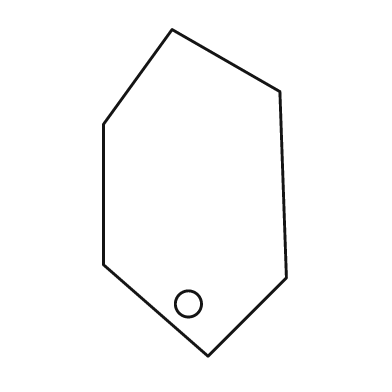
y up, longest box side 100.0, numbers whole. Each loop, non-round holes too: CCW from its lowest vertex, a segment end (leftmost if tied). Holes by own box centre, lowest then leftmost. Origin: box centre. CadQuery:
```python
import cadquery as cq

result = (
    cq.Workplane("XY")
    .moveTo(4.0, -50.0)
    .lineTo(28.0, -26.0)
    .lineTo(26.0, 31.0)
    .lineTo(-7.0, 50.0)
    .lineTo(-28.0, 21.0)
    .lineTo(-28.0, -22.0)
    .close()
    .moveTo(-2.0, -34.0)
    .circle(4.0)
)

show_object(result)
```